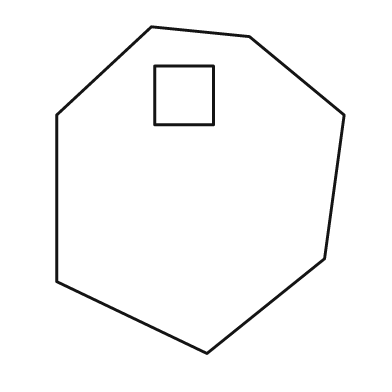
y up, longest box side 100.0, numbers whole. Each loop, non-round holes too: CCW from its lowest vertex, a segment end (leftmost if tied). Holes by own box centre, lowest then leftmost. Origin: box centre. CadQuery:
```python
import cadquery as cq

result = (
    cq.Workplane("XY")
    .moveTo(2.0, -50.0)
    .lineTo(38.0, -21.0)
    .lineTo(44.0, 23.0)
    .lineTo(15.0, 47.0)
    .lineTo(-15.0, 50.0)
    .lineTo(-44.0, 23.0)
    .lineTo(-44.0, -28.0)
    .close()
    .moveTo(-14.0, 20.0)
    .lineTo(4.0, 20.0)
    .lineTo(4.0, 38.0)
    .lineTo(-14.0, 38.0)
    .close()
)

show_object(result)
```